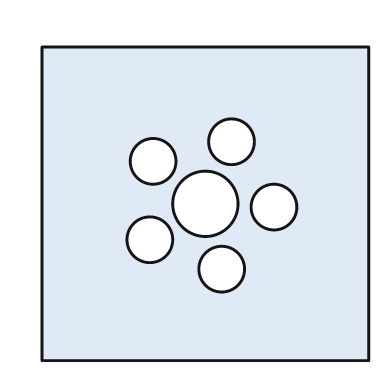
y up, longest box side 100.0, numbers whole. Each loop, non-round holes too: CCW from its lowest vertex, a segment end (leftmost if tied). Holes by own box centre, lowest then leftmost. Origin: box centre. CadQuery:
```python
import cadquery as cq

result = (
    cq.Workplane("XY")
    .moveTo(-50.0, -48.0)
    .lineTo(50.0, -48.0)
    .lineTo(50.0, 48.0)
    .lineTo(-50.0, 48.0)
    .close()
    .moveTo(5.0, -20.0)
    .circle(7.0)
    .moveTo(-17.0, -11.0)
    .circle(7.0)
    .moveTo(21.0, -1.0)
    .circle(7.0)
    .moveTo(0.0, 0.0)
    .circle(10.0)
    .moveTo(-16.0, 13.0)
    .circle(7.0)
    .moveTo(8.0, 19.0)
    .circle(7.0)
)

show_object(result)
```